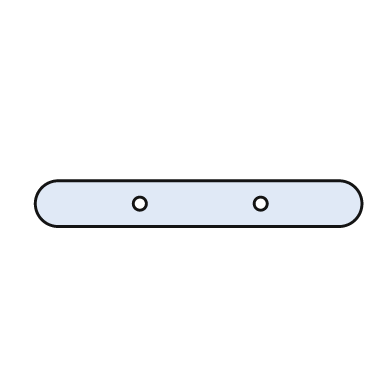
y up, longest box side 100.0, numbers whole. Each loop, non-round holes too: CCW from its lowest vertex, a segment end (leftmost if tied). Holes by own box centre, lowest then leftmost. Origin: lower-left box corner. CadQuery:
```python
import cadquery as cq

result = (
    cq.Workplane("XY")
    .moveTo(7.0, 0.0)
    .lineTo(93.0, 0.0)
    .threePointArc((100.0, 7.0), (93.0, 14.0))
    .lineTo(7.0, 14.0)
    .threePointArc((0.0, 7.0), (7.0, 0.0))
    .close()
    .moveTo(32.0, 7.0)
    .circle(2.0)
    .moveTo(69.0, 7.0)
    .circle(2.0)
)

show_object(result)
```